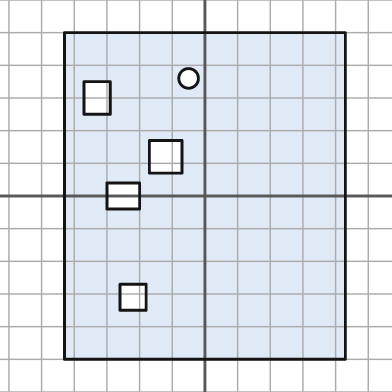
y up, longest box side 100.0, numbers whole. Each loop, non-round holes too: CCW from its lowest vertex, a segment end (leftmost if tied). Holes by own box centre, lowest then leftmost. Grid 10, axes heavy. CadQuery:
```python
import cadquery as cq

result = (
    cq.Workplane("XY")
    .moveTo(-43.0, -50.0)
    .lineTo(43.0, -50.0)
    .lineTo(43.0, 50.0)
    .lineTo(-43.0, 50.0)
    .close()
    .moveTo(-26.0, -35.0)
    .lineTo(-18.0, -35.0)
    .lineTo(-18.0, -27.0)
    .lineTo(-26.0, -27.0)
    .close()
    .moveTo(-30.0, -4.0)
    .lineTo(-20.0, -4.0)
    .lineTo(-20.0, 4.0)
    .lineTo(-30.0, 4.0)
    .close()
    .moveTo(-17.0, 7.0)
    .lineTo(-7.0, 7.0)
    .lineTo(-7.0, 17.0)
    .lineTo(-17.0, 17.0)
    .close()
    .moveTo(-37.0, 25.0)
    .lineTo(-29.0, 25.0)
    .lineTo(-29.0, 35.0)
    .lineTo(-37.0, 35.0)
    .close()
    .moveTo(-5.0, 36.0)
    .circle(3.0)
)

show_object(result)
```